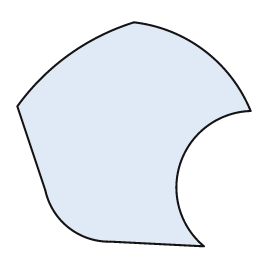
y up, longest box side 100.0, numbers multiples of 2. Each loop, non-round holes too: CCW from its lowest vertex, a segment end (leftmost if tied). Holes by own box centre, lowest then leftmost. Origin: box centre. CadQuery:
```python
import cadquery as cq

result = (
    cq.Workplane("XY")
    .moveTo(30.0, -48.0)
    .threePointArc((20.0, -12.0), (50.0, 10.0))
    .threePointArc((30.0, 36.0), (0.0, 48.0))
    .threePointArc((-28.0, 34.0), (-50.0, 12.0))
    .lineTo(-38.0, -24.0)
    .threePointArc((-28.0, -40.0), (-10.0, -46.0))
    .close()
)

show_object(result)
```